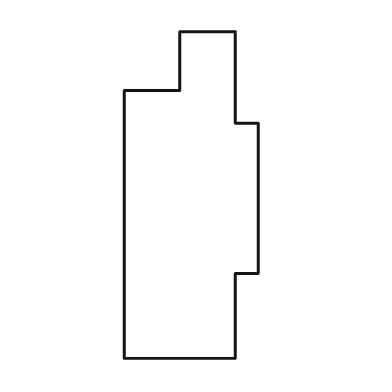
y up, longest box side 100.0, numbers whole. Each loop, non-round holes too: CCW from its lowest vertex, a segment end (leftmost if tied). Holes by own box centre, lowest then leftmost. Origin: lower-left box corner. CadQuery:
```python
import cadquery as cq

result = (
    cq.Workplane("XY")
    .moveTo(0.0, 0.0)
    .lineTo(34.0, 0.0)
    .lineTo(34.0, 26.0)
    .lineTo(41.0, 26.0)
    .lineTo(41.0, 72.0)
    .lineTo(34.0, 72.0)
    .lineTo(34.0, 100.0)
    .lineTo(17.0, 100.0)
    .lineTo(17.0, 82.0)
    .lineTo(0.0, 82.0)
    .close()
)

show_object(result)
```